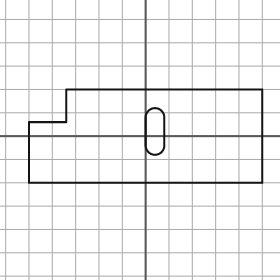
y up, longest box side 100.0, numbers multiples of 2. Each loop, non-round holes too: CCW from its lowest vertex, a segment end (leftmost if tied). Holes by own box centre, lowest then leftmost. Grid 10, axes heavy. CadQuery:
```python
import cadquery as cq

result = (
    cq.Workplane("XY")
    .moveTo(-50.0, -20.0)
    .lineTo(50.0, -20.0)
    .lineTo(50.0, 20.0)
    .lineTo(-34.0, 20.0)
    .lineTo(-34.0, 6.0)
    .lineTo(-50.0, 6.0)
    .close()
    .moveTo(0.0, -4.0)
    .threePointArc((4.0, -8.0), (8.0, -4.0))
    .lineTo(8.0, 8.0)
    .threePointArc((4.0, 12.0), (0.0, 8.0))
    .close()
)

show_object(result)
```